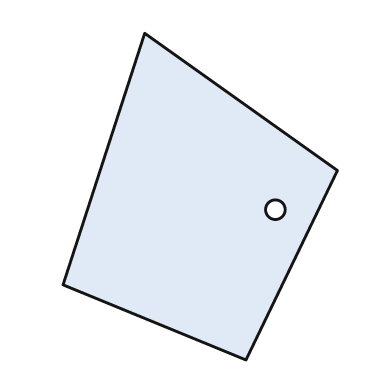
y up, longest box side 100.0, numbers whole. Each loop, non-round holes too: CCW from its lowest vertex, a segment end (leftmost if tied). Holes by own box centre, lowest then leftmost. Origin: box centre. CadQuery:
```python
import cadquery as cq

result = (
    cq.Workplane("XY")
    .moveTo(14.0, -50.0)
    .lineTo(42.0, 8.0)
    .lineTo(-17.0, 50.0)
    .lineTo(-42.0, -27.0)
    .close()
    .moveTo(23.0, -4.0)
    .circle(3.0)
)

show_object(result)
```